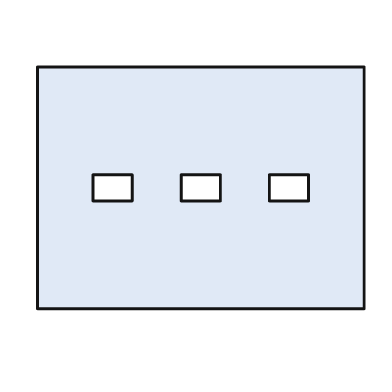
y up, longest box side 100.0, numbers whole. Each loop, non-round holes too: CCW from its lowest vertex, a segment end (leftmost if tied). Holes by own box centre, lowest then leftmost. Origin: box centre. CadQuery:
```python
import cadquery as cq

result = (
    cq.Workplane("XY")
    .moveTo(-50.0, -37.0)
    .lineTo(50.0, -37.0)
    .lineTo(50.0, 37.0)
    .lineTo(-50.0, 37.0)
    .close()
    .moveTo(-33.0, -4.0)
    .lineTo(-21.0, -4.0)
    .lineTo(-21.0, 4.0)
    .lineTo(-33.0, 4.0)
    .close()
    .moveTo(-6.0, -4.0)
    .lineTo(6.0, -4.0)
    .lineTo(6.0, 4.0)
    .lineTo(-6.0, 4.0)
    .close()
    .moveTo(21.0, -4.0)
    .lineTo(33.0, -4.0)
    .lineTo(33.0, 4.0)
    .lineTo(21.0, 4.0)
    .close()
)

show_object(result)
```